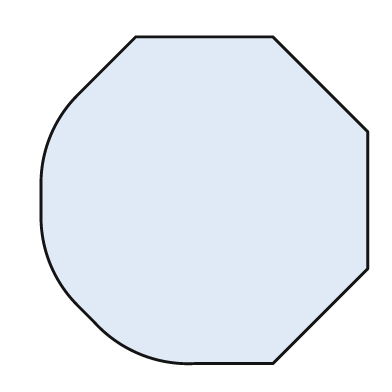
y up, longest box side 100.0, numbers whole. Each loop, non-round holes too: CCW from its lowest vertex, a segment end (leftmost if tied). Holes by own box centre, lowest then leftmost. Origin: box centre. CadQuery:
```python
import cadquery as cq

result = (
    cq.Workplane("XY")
    .moveTo(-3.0, -50.0)
    .lineTo(21.0, -50.0)
    .lineTo(50.0, -21.0)
    .lineTo(50.0, 21.0)
    .lineTo(21.0, 50.0)
    .lineTo(-21.0, 50.0)
    .lineTo(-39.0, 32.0)
    .threePointArc((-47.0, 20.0), (-50.0, 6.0))
    .lineTo(-50.0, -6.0)
    .threePointArc((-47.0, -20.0), (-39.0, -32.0))
    .lineTo(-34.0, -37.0)
    .threePointArc((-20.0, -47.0), (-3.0, -50.0))
    .close()
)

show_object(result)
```